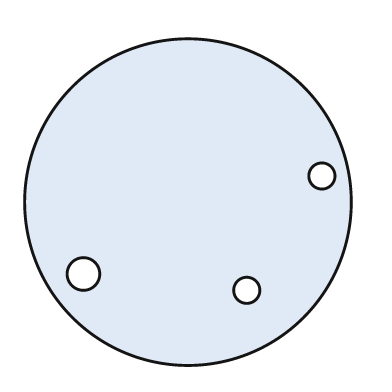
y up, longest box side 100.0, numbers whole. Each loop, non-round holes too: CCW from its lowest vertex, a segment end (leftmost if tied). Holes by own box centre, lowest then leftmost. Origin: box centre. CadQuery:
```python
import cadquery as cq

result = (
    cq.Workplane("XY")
    .moveTo(0.0, 0.0)
    .circle(50.0)
    .moveTo(18.0, -27.0)
    .circle(4.0)
    .moveTo(-32.0, -22.0)
    .circle(5.0)
    .moveTo(41.0, 8.0)
    .circle(4.0)
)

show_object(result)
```